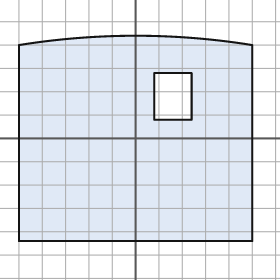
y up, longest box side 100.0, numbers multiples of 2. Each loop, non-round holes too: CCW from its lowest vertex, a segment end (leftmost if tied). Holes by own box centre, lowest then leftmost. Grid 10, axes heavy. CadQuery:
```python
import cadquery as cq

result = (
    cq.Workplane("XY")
    .moveTo(-50.0, -44.0)
    .lineTo(50.0, -44.0)
    .lineTo(50.0, 40.0)
    .threePointArc((0.0, 44.0), (-50.0, 40.0))
    .close()
    .moveTo(8.0, 8.0)
    .lineTo(24.0, 8.0)
    .lineTo(24.0, 28.0)
    .lineTo(8.0, 28.0)
    .close()
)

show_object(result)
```